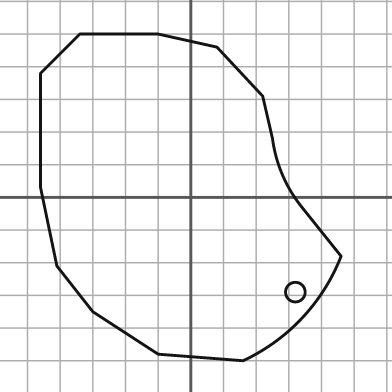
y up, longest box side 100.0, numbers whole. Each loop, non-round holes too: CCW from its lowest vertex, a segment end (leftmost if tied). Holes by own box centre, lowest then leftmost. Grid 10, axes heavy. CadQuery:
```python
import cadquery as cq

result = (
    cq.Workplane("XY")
    .moveTo(16.0, -50.0)
    .threePointArc((34.0, -37.0), (46.0, -18.0))
    .lineTo(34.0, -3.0)
    .threePointArc((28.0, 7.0), (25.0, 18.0))
    .lineTo(22.0, 31.0)
    .lineTo(8.0, 46.0)
    .lineTo(-10.0, 50.0)
    .lineTo(-34.0, 50.0)
    .lineTo(-46.0, 38.0)
    .lineTo(-46.0, 3.0)
    .lineTo(-41.0, -21.0)
    .lineTo(-30.0, -35.0)
    .lineTo(-10.0, -48.0)
    .close()
    .moveTo(32.0, -29.0)
    .circle(3.0)
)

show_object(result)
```